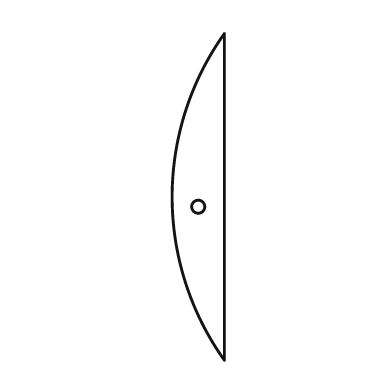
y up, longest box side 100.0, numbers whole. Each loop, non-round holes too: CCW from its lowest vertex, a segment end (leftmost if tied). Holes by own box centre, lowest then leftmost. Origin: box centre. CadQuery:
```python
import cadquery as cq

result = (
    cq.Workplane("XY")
    .moveTo(8.0, -50.0)
    .lineTo(8.0, 50.0)
    .threePointArc((-8.0, 0.0), (8.0, -50.0))
    .close()
    .moveTo(0.0, -3.0)
    .circle(2.0)
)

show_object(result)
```